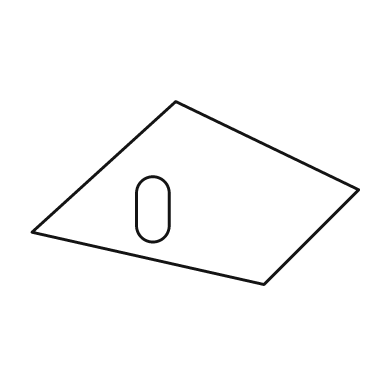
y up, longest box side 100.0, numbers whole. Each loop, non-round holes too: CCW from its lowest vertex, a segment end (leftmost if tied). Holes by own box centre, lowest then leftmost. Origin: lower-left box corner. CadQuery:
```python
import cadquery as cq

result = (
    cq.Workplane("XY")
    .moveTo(71.0, 0.0)
    .lineTo(100.0, 29.0)
    .lineTo(44.0, 56.0)
    .lineTo(0.0, 16.0)
    .close()
    .moveTo(32.0, 18.0)
    .threePointArc((37.0, 13.0), (42.0, 18.0))
    .lineTo(42.0, 28.0)
    .threePointArc((37.0, 33.0), (32.0, 28.0))
    .close()
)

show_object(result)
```